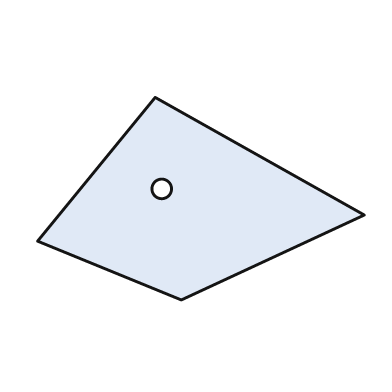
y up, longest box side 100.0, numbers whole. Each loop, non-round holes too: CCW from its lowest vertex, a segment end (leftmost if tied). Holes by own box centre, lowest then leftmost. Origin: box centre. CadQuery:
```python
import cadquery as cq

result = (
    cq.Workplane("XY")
    .moveTo(-6.0, -31.0)
    .lineTo(50.0, -5.0)
    .lineTo(-14.0, 31.0)
    .lineTo(-50.0, -13.0)
    .close()
    .moveTo(-12.0, 3.0)
    .circle(3.0)
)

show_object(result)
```